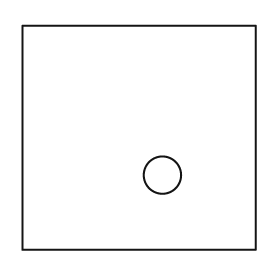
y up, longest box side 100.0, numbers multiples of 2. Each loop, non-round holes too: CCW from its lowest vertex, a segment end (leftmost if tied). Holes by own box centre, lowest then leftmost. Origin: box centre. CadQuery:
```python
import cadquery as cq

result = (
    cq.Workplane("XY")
    .moveTo(-50.0, -48.0)
    .lineTo(50.0, -48.0)
    .lineTo(50.0, 48.0)
    .lineTo(-50.0, 48.0)
    .close()
    .moveTo(10.0, -16.0)
    .circle(8.0)
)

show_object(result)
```